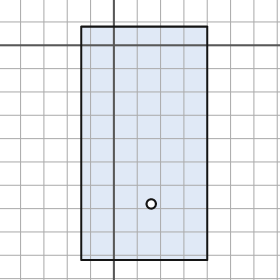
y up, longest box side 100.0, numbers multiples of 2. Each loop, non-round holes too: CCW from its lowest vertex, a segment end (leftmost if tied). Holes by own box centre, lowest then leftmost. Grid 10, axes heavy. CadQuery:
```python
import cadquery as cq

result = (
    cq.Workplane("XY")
    .moveTo(-14.0, -92.0)
    .lineTo(40.0, -92.0)
    .lineTo(40.0, 8.0)
    .lineTo(-14.0, 8.0)
    .close()
    .moveTo(16.0, -68.0)
    .circle(2.0)
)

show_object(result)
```